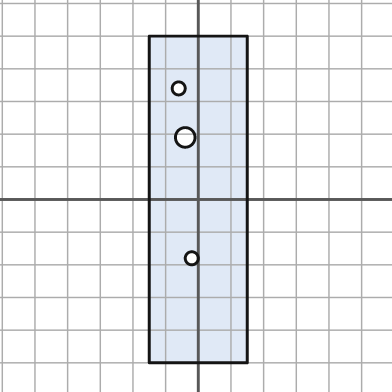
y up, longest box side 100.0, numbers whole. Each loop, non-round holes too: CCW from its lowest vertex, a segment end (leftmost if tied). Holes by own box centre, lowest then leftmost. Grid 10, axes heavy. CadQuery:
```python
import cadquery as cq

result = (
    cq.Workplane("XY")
    .moveTo(-15.0, -50.0)
    .lineTo(15.0, -50.0)
    .lineTo(15.0, 50.0)
    .lineTo(-15.0, 50.0)
    .close()
    .moveTo(-2.0, -18.0)
    .circle(2.0)
    .moveTo(-4.0, 19.0)
    .circle(3.0)
    .moveTo(-6.0, 34.0)
    .circle(2.0)
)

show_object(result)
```